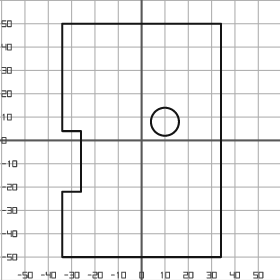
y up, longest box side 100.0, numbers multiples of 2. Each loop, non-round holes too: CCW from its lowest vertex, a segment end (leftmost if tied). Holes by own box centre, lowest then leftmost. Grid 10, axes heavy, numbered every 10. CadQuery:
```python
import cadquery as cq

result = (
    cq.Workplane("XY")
    .moveTo(-34.0, -50.0)
    .lineTo(34.0, -50.0)
    .lineTo(34.0, 50.0)
    .lineTo(-34.0, 50.0)
    .lineTo(-34.0, 4.0)
    .lineTo(-26.0, 4.0)
    .lineTo(-26.0, -22.0)
    .lineTo(-34.0, -22.0)
    .close()
    .moveTo(10.0, 8.0)
    .circle(6.0)
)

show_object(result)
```